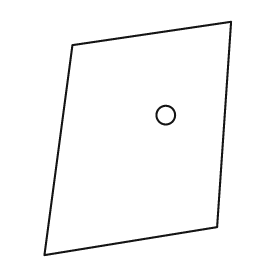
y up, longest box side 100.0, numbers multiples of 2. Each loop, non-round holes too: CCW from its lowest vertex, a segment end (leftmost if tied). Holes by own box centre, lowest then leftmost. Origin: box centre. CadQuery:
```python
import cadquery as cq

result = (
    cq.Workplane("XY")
    .moveTo(-40.0, -50.0)
    .lineTo(34.0, -38.0)
    .lineTo(40.0, 50.0)
    .lineTo(-28.0, 40.0)
    .close()
    .moveTo(12.0, 10.0)
    .circle(4.0)
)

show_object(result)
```